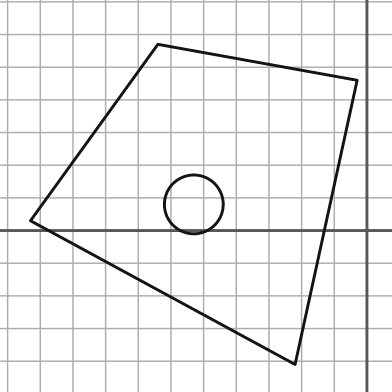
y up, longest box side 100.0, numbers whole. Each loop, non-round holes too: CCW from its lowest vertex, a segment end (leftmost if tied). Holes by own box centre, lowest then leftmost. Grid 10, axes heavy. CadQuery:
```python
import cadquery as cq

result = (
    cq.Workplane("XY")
    .moveTo(-22.0, -41.0)
    .lineTo(-3.0, 46.0)
    .lineTo(-64.0, 57.0)
    .lineTo(-103.0, 3.0)
    .close()
    .moveTo(-53.0, 8.0)
    .circle(9.0)
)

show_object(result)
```